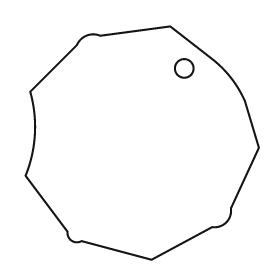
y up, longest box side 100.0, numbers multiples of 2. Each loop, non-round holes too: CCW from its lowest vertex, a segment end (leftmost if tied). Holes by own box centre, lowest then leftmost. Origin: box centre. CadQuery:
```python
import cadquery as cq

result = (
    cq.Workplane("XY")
    .moveTo(4.0, -50.0)
    .lineTo(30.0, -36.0)
    .threePointArc((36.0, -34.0), (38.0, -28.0))
    .lineTo(50.0, -2.0)
    .lineTo(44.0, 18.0)
    .threePointArc((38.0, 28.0), (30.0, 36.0))
    .lineTo(12.0, 50.0)
    .lineTo(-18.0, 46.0)
    .threePointArc((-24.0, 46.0), (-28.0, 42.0))
    .lineTo(-48.0, 22.0)
    .threePointArc((-46.0, 4.0), (-50.0, -14.0))
    .lineTo(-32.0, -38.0)
    .threePointArc((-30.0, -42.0), (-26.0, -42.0))
    .close()
    .moveTo(18.0, 32.0)
    .circle(4.0)
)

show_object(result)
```